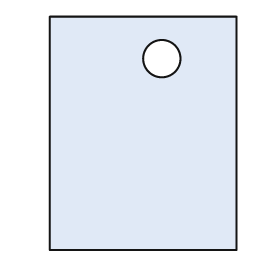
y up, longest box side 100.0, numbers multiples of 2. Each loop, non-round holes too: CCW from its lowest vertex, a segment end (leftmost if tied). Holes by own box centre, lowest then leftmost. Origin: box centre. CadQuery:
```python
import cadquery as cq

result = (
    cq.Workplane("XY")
    .moveTo(-40.0, -50.0)
    .lineTo(40.0, -50.0)
    .lineTo(40.0, 50.0)
    .lineTo(-40.0, 50.0)
    .close()
    .moveTo(8.0, 32.0)
    .circle(8.0)
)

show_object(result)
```